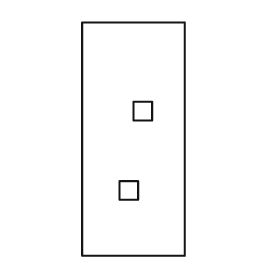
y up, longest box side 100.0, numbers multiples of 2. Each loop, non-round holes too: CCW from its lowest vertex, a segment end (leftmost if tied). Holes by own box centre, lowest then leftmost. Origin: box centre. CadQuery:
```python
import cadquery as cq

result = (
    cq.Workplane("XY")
    .moveTo(-22.0, -50.0)
    .lineTo(22.0, -50.0)
    .lineTo(22.0, 50.0)
    .lineTo(-22.0, 50.0)
    .close()
    .moveTo(-6.0, -26.0)
    .lineTo(2.0, -26.0)
    .lineTo(2.0, -18.0)
    .lineTo(-6.0, -18.0)
    .close()
    .moveTo(0.0, 8.0)
    .lineTo(8.0, 8.0)
    .lineTo(8.0, 16.0)
    .lineTo(0.0, 16.0)
    .close()
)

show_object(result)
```